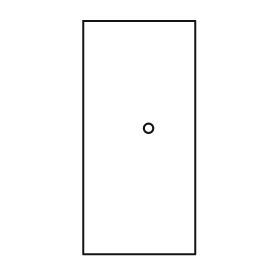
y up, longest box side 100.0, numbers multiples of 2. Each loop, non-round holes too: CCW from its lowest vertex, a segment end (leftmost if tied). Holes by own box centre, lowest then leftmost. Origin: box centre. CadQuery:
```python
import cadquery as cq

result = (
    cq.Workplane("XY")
    .moveTo(-24.0, -50.0)
    .lineTo(24.0, -50.0)
    .lineTo(24.0, 50.0)
    .lineTo(-24.0, 50.0)
    .close()
    .moveTo(4.0, 4.0)
    .circle(2.0)
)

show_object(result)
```